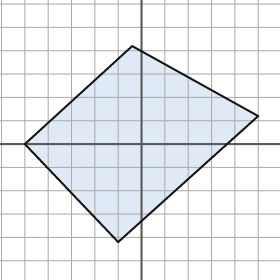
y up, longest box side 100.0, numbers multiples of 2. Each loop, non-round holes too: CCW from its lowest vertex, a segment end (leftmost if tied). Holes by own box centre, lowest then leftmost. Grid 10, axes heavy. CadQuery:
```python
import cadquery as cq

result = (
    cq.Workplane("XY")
    .moveTo(-10.0, -42.0)
    .lineTo(50.0, 12.0)
    .lineTo(-4.0, 42.0)
    .lineTo(-50.0, 0.0)
    .close()
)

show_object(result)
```